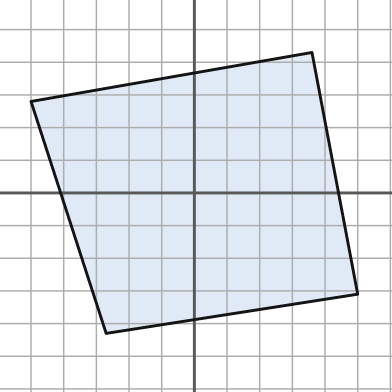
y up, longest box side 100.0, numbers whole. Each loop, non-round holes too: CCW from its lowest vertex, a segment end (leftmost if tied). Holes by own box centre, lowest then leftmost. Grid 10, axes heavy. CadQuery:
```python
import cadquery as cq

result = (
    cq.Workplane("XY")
    .moveTo(-27.0, -43.0)
    .lineTo(50.0, -31.0)
    .lineTo(36.0, 43.0)
    .lineTo(-50.0, 28.0)
    .close()
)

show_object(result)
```